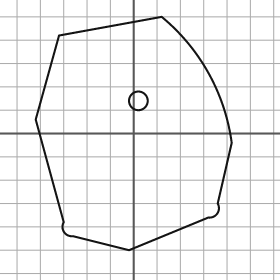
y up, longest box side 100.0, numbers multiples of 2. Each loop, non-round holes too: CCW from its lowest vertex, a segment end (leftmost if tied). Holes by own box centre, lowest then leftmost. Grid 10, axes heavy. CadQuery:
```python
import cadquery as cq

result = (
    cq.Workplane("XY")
    .moveTo(-2.0, -50.0)
    .lineTo(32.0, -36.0)
    .threePointArc((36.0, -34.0), (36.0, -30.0))
    .lineTo(42.0, -4.0)
    .threePointArc((32.0, 26.0), (12.0, 50.0))
    .lineTo(-32.0, 42.0)
    .lineTo(-42.0, 6.0)
    .lineTo(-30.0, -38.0)
    .threePointArc((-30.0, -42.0), (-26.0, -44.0))
    .close()
    .moveTo(2.0, 14.0)
    .circle(4.0)
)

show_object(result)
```